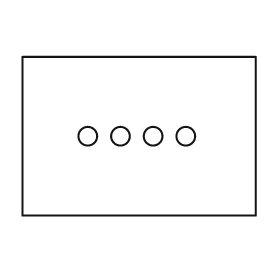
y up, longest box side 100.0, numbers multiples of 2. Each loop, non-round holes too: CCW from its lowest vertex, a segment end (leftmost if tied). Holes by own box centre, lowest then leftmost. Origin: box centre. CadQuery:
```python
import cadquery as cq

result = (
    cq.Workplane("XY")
    .moveTo(-50.0, -34.0)
    .lineTo(50.0, -34.0)
    .lineTo(50.0, 34.0)
    .lineTo(-50.0, 34.0)
    .close()
    .moveTo(-22.0, 0.0)
    .circle(4.0)
    .moveTo(-8.0, 0.0)
    .circle(4.0)
    .moveTo(6.0, 0.0)
    .circle(4.0)
    .moveTo(20.0, 0.0)
    .circle(4.0)
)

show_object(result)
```